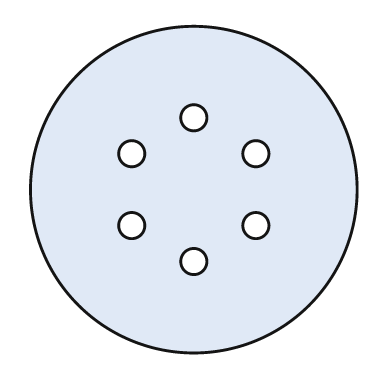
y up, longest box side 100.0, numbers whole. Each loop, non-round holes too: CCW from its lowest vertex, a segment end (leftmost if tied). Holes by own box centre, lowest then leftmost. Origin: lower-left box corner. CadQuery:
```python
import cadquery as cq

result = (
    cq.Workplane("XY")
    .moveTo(50.0, 50.0)
    .circle(50.0)
    .moveTo(50.0, 28.0)
    .circle(4.0)
    .moveTo(31.0, 39.0)
    .circle(4.0)
    .moveTo(69.0, 39.0)
    .circle(4.0)
    .moveTo(31.0, 61.0)
    .circle(4.0)
    .moveTo(69.0, 61.0)
    .circle(4.0)
    .moveTo(50.0, 72.0)
    .circle(4.0)
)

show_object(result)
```